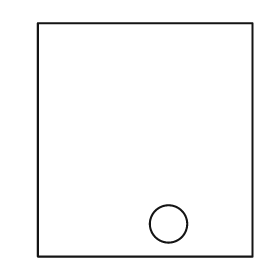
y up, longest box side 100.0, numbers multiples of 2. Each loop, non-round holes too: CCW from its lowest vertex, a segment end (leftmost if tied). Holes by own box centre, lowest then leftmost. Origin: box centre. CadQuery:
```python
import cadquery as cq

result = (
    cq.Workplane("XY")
    .moveTo(-46.0, -50.0)
    .lineTo(46.0, -50.0)
    .lineTo(46.0, 50.0)
    .lineTo(-46.0, 50.0)
    .close()
    .moveTo(10.0, -36.0)
    .circle(8.0)
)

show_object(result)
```